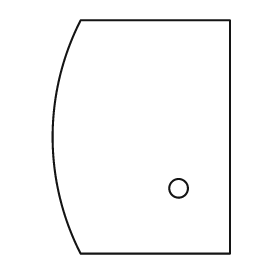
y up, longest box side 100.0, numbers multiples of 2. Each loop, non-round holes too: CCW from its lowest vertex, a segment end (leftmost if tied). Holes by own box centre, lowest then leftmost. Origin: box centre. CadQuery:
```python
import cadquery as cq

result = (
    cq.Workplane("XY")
    .moveTo(-26.0, -50.0)
    .lineTo(38.0, -50.0)
    .lineTo(38.0, 50.0)
    .lineTo(-26.0, 50.0)
    .threePointArc((-38.0, 0.0), (-26.0, -50.0))
    .close()
    .moveTo(16.0, -22.0)
    .circle(4.0)
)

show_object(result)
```